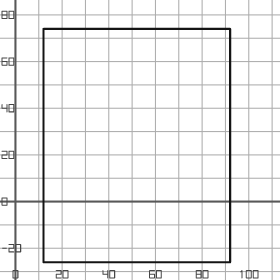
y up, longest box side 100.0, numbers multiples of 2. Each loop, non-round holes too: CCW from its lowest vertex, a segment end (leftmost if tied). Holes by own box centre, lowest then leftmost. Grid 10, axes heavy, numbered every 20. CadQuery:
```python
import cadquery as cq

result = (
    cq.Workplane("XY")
    .moveTo(12.0, -26.0)
    .lineTo(92.0, -26.0)
    .lineTo(92.0, 74.0)
    .lineTo(12.0, 74.0)
    .close()
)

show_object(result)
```